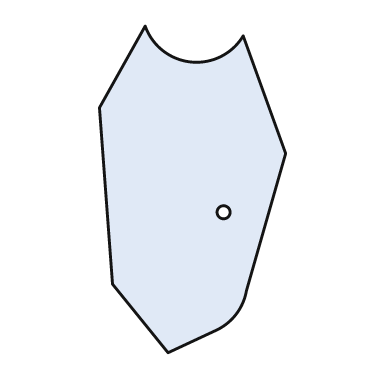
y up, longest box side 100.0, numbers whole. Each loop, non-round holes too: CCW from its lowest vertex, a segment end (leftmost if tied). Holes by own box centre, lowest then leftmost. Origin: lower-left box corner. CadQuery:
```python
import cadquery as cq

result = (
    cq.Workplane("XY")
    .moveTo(21.0, 0.0)
    .lineTo(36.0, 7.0)
    .threePointArc((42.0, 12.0), (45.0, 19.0))
    .lineTo(57.0, 61.0)
    .lineTo(44.0, 97.0)
    .threePointArc((28.0, 89.0), (14.0, 100.0))
    .lineTo(0.0, 75.0)
    .lineTo(4.0, 21.0)
    .close()
    .moveTo(38.0, 43.0)
    .circle(2.0)
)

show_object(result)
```